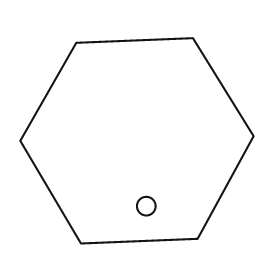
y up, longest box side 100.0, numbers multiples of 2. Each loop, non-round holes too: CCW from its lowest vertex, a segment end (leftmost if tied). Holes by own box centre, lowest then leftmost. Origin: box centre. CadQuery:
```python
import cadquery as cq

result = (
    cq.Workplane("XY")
    .moveTo(-24.0, -44.0)
    .lineTo(26.0, -42.0)
    .lineTo(50.0, 2.0)
    .lineTo(24.0, 44.0)
    .lineTo(-26.0, 42.0)
    .lineTo(-50.0, 0.0)
    .close()
    .moveTo(4.0, -28.0)
    .circle(4.0)
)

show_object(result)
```